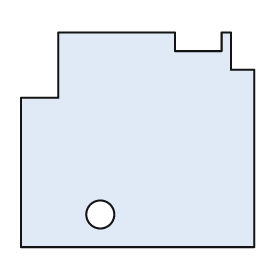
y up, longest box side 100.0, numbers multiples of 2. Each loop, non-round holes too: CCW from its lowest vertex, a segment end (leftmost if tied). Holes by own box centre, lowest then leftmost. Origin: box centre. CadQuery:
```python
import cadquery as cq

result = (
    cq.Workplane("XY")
    .moveTo(-50.0, -46.0)
    .lineTo(50.0, -46.0)
    .lineTo(50.0, 30.0)
    .lineTo(40.0, 30.0)
    .lineTo(40.0, 46.0)
    .lineTo(36.0, 46.0)
    .lineTo(36.0, 38.0)
    .lineTo(16.0, 38.0)
    .lineTo(16.0, 46.0)
    .lineTo(-34.0, 46.0)
    .lineTo(-34.0, 18.0)
    .lineTo(-50.0, 18.0)
    .close()
    .moveTo(-16.0, -32.0)
    .circle(6.0)
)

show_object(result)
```